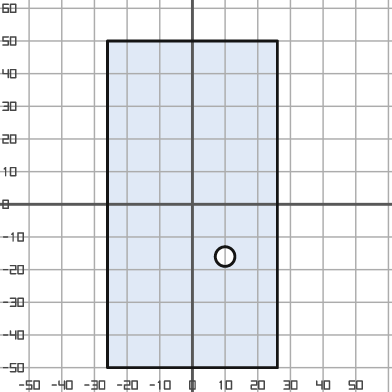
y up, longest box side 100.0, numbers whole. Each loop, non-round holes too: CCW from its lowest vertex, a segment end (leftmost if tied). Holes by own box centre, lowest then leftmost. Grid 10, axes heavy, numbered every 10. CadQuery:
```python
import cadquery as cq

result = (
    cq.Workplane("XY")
    .moveTo(-26.0, -50.0)
    .lineTo(26.0, -50.0)
    .lineTo(26.0, 50.0)
    .lineTo(-26.0, 50.0)
    .close()
    .moveTo(10.0, -16.0)
    .circle(3.0)
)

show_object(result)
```